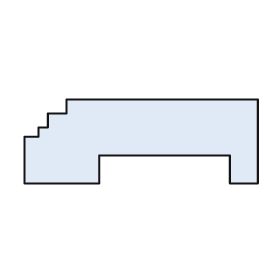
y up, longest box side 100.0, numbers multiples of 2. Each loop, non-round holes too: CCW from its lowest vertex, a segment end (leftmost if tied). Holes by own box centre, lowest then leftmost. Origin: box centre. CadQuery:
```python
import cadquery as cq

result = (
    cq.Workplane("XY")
    .moveTo(-50.0, -18.0)
    .lineTo(-18.0, -18.0)
    .lineTo(-18.0, -6.0)
    .lineTo(38.0, -6.0)
    .lineTo(38.0, -18.0)
    .lineTo(50.0, -18.0)
    .lineTo(50.0, 18.0)
    .lineTo(-32.0, 18.0)
    .lineTo(-32.0, 12.0)
    .lineTo(-40.0, 12.0)
    .lineTo(-40.0, 6.0)
    .lineTo(-44.0, 6.0)
    .lineTo(-44.0, 2.0)
    .lineTo(-50.0, 2.0)
    .close()
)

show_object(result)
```